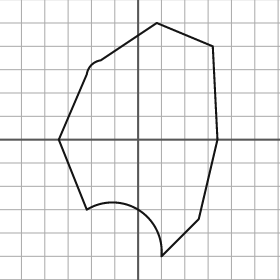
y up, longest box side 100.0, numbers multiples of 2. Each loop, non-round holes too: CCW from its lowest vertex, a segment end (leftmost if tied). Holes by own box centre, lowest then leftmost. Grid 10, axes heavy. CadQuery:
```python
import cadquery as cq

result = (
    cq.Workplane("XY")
    .moveTo(10.0, -50.0)
    .lineTo(26.0, -34.0)
    .lineTo(34.0, 0.0)
    .lineTo(32.0, 40.0)
    .lineTo(8.0, 50.0)
    .lineTo(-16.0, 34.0)
    .threePointArc((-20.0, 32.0), (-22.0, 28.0))
    .lineTo(-34.0, 0.0)
    .lineTo(-22.0, -30.0)
    .threePointArc((0.0, -30.0), (10.0, -50.0))
    .close()
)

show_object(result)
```